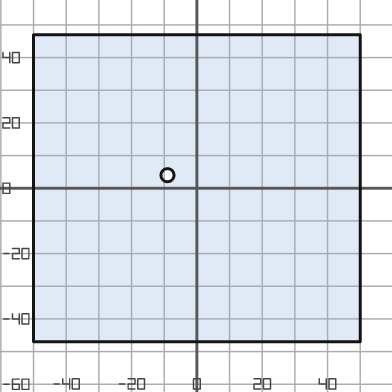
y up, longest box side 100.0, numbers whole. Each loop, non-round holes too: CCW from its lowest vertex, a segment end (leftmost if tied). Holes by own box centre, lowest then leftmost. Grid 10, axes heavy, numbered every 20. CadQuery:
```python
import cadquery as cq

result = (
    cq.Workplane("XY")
    .moveTo(-50.0, -47.0)
    .lineTo(50.0, -47.0)
    .lineTo(50.0, 47.0)
    .lineTo(-50.0, 47.0)
    .close()
    .moveTo(-9.0, 4.0)
    .circle(2.0)
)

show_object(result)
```